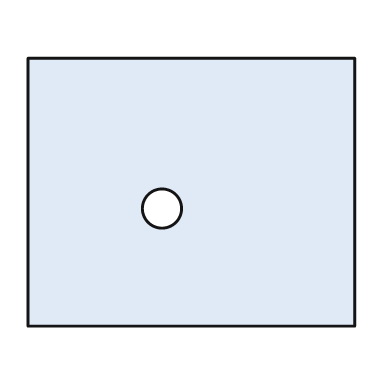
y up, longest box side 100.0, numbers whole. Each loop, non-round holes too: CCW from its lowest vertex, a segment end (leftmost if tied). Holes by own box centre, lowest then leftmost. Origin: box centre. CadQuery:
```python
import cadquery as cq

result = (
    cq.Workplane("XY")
    .moveTo(-50.0, -41.0)
    .lineTo(50.0, -41.0)
    .lineTo(50.0, 41.0)
    .lineTo(-50.0, 41.0)
    .close()
    .moveTo(-9.0, -5.0)
    .circle(6.0)
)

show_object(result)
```